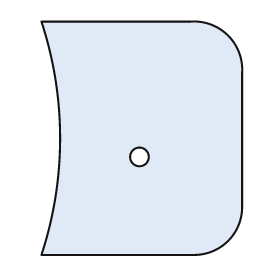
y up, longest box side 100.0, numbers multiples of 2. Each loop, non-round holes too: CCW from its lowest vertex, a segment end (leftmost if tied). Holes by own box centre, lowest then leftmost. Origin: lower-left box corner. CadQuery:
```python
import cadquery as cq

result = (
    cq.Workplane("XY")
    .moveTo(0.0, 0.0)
    .lineTo(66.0, 0.0)
    .threePointArc((80.0, 6.0), (86.0, 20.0))
    .lineTo(86.0, 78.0)
    .threePointArc((80.0, 94.0), (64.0, 100.0))
    .lineTo(0.0, 100.0)
    .threePointArc((8.0, 50.0), (0.0, 0.0))
    .close()
    .moveTo(42.0, 42.0)
    .circle(4.0)
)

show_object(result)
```